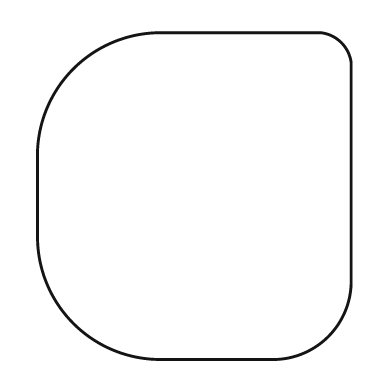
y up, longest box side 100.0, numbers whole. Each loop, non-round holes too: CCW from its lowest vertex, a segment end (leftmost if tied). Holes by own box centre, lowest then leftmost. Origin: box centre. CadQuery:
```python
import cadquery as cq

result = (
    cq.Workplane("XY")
    .moveTo(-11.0, -50.0)
    .lineTo(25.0, -50.0)
    .threePointArc((41.0, -43.0), (48.0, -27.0))
    .lineTo(48.0, 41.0)
    .threePointArc((45.0, 47.0), (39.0, 50.0))
    .lineTo(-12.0, 50.0)
    .threePointArc((-37.0, 39.0), (-48.0, 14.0))
    .lineTo(-48.0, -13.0)
    .threePointArc((-37.0, -39.0), (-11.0, -50.0))
    .close()
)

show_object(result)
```